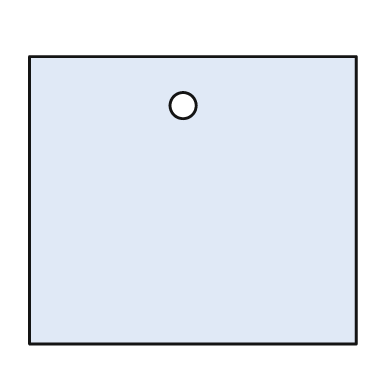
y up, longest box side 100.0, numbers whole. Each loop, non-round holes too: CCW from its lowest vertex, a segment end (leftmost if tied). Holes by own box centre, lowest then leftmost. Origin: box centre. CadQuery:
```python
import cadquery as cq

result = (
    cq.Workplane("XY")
    .moveTo(-50.0, -44.0)
    .lineTo(50.0, -44.0)
    .lineTo(50.0, 44.0)
    .lineTo(-50.0, 44.0)
    .close()
    .moveTo(-3.0, 29.0)
    .circle(4.0)
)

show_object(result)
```